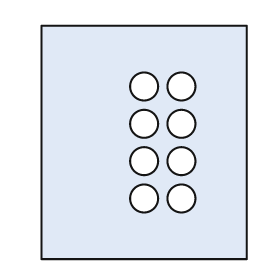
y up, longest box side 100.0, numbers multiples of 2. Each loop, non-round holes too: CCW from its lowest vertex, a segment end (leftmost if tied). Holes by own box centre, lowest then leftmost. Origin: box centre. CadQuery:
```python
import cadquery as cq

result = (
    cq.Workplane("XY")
    .moveTo(-44.0, -50.0)
    .lineTo(44.0, -50.0)
    .lineTo(44.0, 50.0)
    .lineTo(-44.0, 50.0)
    .close()
    .moveTo(0.0, -24.0)
    .circle(6.0)
    .moveTo(16.0, -24.0)
    .circle(6.0)
    .moveTo(0.0, -8.0)
    .circle(6.0)
    .moveTo(16.0, -8.0)
    .circle(6.0)
    .moveTo(0.0, 8.0)
    .circle(6.0)
    .moveTo(16.0, 8.0)
    .circle(6.0)
    .moveTo(0.0, 24.0)
    .circle(6.0)
    .moveTo(16.0, 24.0)
    .circle(6.0)
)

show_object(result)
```